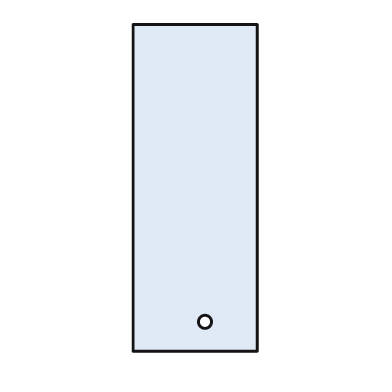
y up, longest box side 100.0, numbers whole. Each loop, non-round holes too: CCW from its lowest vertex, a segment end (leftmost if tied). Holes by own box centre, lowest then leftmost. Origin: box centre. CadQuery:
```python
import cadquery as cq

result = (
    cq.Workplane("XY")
    .moveTo(-19.0, -50.0)
    .lineTo(19.0, -50.0)
    .lineTo(19.0, 50.0)
    .lineTo(-19.0, 50.0)
    .close()
    .moveTo(3.0, -41.0)
    .circle(2.0)
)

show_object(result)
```